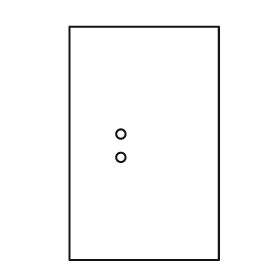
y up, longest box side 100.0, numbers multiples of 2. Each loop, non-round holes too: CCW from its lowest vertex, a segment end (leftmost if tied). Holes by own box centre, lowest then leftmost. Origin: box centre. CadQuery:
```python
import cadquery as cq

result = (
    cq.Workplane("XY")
    .moveTo(-32.0, -50.0)
    .lineTo(32.0, -50.0)
    .lineTo(32.0, 50.0)
    .lineTo(-32.0, 50.0)
    .close()
    .moveTo(-10.0, -6.0)
    .circle(2.0)
    .moveTo(-10.0, 4.0)
    .circle(2.0)
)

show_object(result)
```